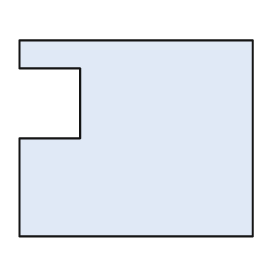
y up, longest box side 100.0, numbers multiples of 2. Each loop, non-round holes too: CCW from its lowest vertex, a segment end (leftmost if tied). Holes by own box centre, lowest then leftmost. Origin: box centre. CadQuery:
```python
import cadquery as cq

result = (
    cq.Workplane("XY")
    .moveTo(-50.0, -42.0)
    .lineTo(50.0, -42.0)
    .lineTo(50.0, 42.0)
    .lineTo(-50.0, 42.0)
    .lineTo(-50.0, 30.0)
    .lineTo(-24.0, 30.0)
    .lineTo(-24.0, 0.0)
    .lineTo(-50.0, 0.0)
    .close()
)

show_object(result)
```